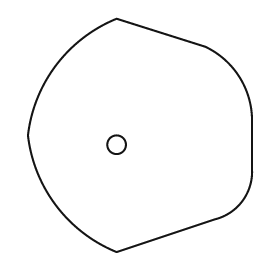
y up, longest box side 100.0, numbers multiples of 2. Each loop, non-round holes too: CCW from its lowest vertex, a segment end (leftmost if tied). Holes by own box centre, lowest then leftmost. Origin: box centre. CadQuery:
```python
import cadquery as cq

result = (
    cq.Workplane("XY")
    .moveTo(-10.0, -50.0)
    .lineTo(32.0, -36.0)
    .threePointArc((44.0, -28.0), (48.0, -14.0))
    .lineTo(48.0, 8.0)
    .threePointArc((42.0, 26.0), (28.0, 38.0))
    .lineTo(-10.0, 50.0)
    .threePointArc((-36.0, 30.0), (-48.0, 0.0))
    .threePointArc((-36.0, -30.0), (-10.0, -50.0))
    .close()
    .moveTo(-10.0, -4.0)
    .circle(4.0)
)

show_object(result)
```